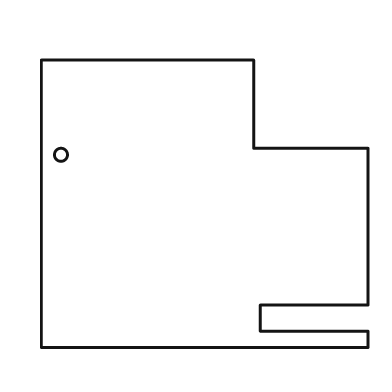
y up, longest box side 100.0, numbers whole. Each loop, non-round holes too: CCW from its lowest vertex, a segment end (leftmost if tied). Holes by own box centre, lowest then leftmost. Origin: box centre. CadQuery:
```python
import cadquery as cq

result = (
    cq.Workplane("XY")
    .moveTo(-50.0, -44.0)
    .lineTo(50.0, -44.0)
    .lineTo(50.0, -39.0)
    .lineTo(17.0, -39.0)
    .lineTo(17.0, -31.0)
    .lineTo(50.0, -31.0)
    .lineTo(50.0, 17.0)
    .lineTo(15.0, 17.0)
    .lineTo(15.0, 44.0)
    .lineTo(-50.0, 44.0)
    .close()
    .moveTo(-44.0, 15.0)
    .circle(2.0)
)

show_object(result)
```